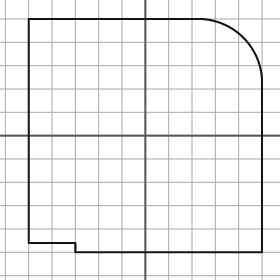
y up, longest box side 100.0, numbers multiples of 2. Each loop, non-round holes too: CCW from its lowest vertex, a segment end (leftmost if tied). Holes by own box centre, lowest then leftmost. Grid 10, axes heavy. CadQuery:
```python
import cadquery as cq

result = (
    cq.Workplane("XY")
    .moveTo(-30.0, -50.0)
    .lineTo(50.0, -50.0)
    .lineTo(50.0, 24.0)
    .threePointArc((42.0, 42.0), (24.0, 50.0))
    .lineTo(-50.0, 50.0)
    .lineTo(-50.0, -46.0)
    .lineTo(-30.0, -46.0)
    .close()
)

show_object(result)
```